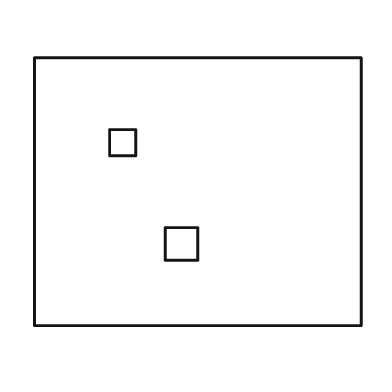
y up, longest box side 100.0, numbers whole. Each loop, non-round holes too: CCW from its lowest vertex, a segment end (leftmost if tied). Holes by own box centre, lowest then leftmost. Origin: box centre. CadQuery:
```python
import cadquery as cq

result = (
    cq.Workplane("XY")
    .moveTo(-50.0, -41.0)
    .lineTo(50.0, -41.0)
    .lineTo(50.0, 41.0)
    .lineTo(-50.0, 41.0)
    .close()
    .moveTo(-10.0, -21.0)
    .lineTo(0.0, -21.0)
    .lineTo(0.0, -11.0)
    .lineTo(-10.0, -11.0)
    .close()
    .moveTo(-27.0, 11.0)
    .lineTo(-19.0, 11.0)
    .lineTo(-19.0, 19.0)
    .lineTo(-27.0, 19.0)
    .close()
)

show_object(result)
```